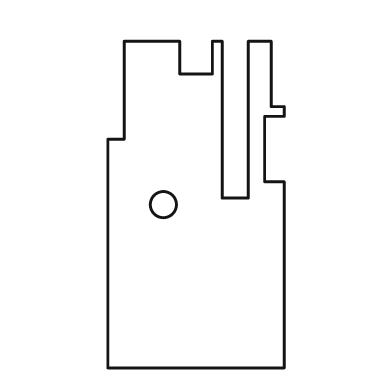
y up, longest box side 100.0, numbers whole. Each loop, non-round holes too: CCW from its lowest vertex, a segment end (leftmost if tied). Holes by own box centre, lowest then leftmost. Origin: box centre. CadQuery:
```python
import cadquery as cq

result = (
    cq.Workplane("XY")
    .moveTo(-27.0, -50.0)
    .lineTo(27.0, -50.0)
    .lineTo(27.0, 7.0)
    .lineTo(21.0, 7.0)
    .lineTo(21.0, 27.0)
    .lineTo(27.0, 27.0)
    .lineTo(27.0, 30.0)
    .lineTo(23.0, 30.0)
    .lineTo(23.0, 50.0)
    .lineTo(16.0, 50.0)
    .lineTo(16.0, 2.0)
    .lineTo(8.0, 2.0)
    .lineTo(8.0, 50.0)
    .lineTo(5.0, 50.0)
    .lineTo(5.0, 40.0)
    .lineTo(-5.0, 40.0)
    .lineTo(-5.0, 50.0)
    .lineTo(-22.0, 50.0)
    .lineTo(-22.0, 20.0)
    .lineTo(-27.0, 20.0)
    .close()
    .moveTo(-10.0, 0.0)
    .circle(4.0)
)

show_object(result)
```